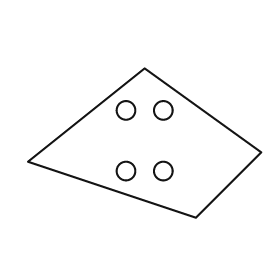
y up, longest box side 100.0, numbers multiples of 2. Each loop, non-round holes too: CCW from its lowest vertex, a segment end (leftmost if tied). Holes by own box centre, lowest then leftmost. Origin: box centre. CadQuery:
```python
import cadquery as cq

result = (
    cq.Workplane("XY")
    .moveTo(22.0, -32.0)
    .lineTo(50.0, -4.0)
    .lineTo(0.0, 32.0)
    .lineTo(-50.0, -8.0)
    .close()
    .moveTo(-8.0, -12.0)
    .circle(4.0)
    .moveTo(8.0, -12.0)
    .circle(4.0)
    .moveTo(-8.0, 14.0)
    .circle(4.0)
    .moveTo(8.0, 14.0)
    .circle(4.0)
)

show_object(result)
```